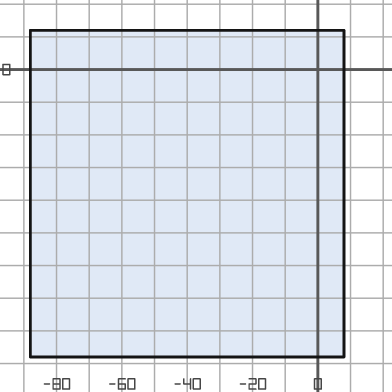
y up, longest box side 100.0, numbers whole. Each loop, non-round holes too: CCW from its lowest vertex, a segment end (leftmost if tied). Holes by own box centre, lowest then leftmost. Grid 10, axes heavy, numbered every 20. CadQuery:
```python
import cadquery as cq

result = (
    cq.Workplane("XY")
    .moveTo(-88.0, -88.0)
    .lineTo(8.0, -88.0)
    .lineTo(8.0, 12.0)
    .lineTo(-88.0, 12.0)
    .close()
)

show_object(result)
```